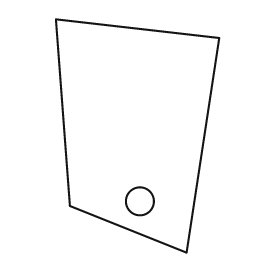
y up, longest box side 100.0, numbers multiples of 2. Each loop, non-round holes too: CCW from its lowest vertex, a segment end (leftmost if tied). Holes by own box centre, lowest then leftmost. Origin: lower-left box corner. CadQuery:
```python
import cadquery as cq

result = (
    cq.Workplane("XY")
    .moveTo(56.0, 0.0)
    .lineTo(70.0, 92.0)
    .lineTo(0.0, 100.0)
    .lineTo(6.0, 20.0)
    .close()
    .moveTo(36.0, 22.0)
    .circle(6.0)
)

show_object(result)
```